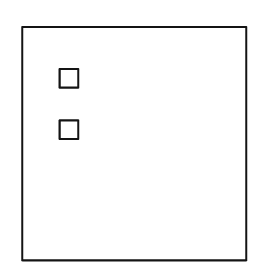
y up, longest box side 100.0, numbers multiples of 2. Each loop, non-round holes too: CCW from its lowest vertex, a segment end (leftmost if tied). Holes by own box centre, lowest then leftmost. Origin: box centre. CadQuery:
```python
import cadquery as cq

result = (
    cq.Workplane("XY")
    .moveTo(-48.0, -50.0)
    .lineTo(48.0, -50.0)
    .lineTo(48.0, 50.0)
    .lineTo(-48.0, 50.0)
    .close()
    .moveTo(-32.0, 2.0)
    .lineTo(-24.0, 2.0)
    .lineTo(-24.0, 10.0)
    .lineTo(-32.0, 10.0)
    .close()
    .moveTo(-32.0, 24.0)
    .lineTo(-24.0, 24.0)
    .lineTo(-24.0, 32.0)
    .lineTo(-32.0, 32.0)
    .close()
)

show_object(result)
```